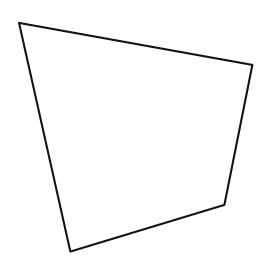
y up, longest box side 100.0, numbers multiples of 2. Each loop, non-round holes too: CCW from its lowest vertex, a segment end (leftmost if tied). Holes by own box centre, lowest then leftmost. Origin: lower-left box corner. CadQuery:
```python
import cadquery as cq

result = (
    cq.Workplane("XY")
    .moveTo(22.0, 0.0)
    .lineTo(88.0, 20.0)
    .lineTo(100.0, 80.0)
    .lineTo(0.0, 98.0)
    .close()
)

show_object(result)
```